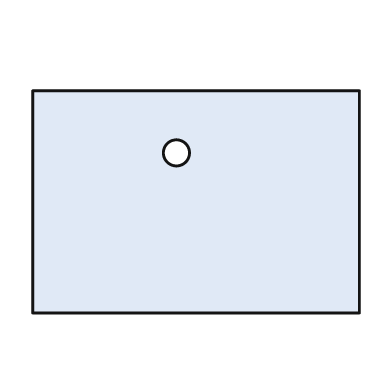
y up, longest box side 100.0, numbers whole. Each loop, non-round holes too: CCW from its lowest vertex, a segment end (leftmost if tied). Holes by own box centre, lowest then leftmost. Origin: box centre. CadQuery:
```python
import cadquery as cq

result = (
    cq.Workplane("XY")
    .moveTo(-50.0, -34.0)
    .lineTo(50.0, -34.0)
    .lineTo(50.0, 34.0)
    .lineTo(-50.0, 34.0)
    .close()
    .moveTo(-6.0, 15.0)
    .circle(4.0)
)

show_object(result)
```